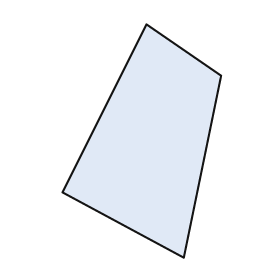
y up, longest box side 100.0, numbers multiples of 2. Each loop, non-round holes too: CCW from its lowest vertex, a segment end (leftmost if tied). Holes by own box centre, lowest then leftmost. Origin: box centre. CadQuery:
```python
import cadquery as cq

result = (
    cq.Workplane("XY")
    .moveTo(18.0, -50.0)
    .lineTo(34.0, 28.0)
    .lineTo(2.0, 50.0)
    .lineTo(-34.0, -22.0)
    .close()
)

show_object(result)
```